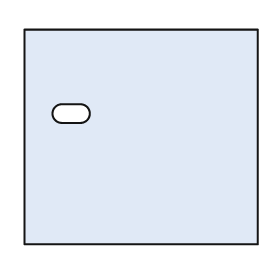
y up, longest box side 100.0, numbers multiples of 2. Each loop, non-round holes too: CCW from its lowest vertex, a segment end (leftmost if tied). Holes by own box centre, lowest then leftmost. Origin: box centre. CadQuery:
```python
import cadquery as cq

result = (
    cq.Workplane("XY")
    .moveTo(-50.0, -46.0)
    .lineTo(50.0, -46.0)
    .lineTo(50.0, 46.0)
    .lineTo(-50.0, 46.0)
    .close()
    .moveTo(-34.0, 6.0)
    .lineTo(-26.0, 6.0)
    .threePointArc((-22.0, 10.0), (-26.0, 14.0))
    .lineTo(-34.0, 14.0)
    .threePointArc((-38.0, 10.0), (-34.0, 6.0))
    .close()
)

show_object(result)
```